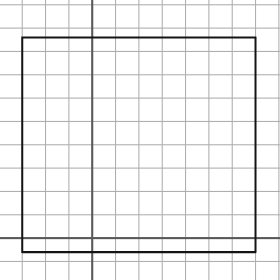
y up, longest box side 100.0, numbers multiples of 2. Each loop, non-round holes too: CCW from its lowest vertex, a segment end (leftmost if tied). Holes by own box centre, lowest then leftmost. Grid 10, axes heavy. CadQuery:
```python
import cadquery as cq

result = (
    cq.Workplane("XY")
    .moveTo(-30.0, -6.0)
    .lineTo(70.0, -6.0)
    .lineTo(70.0, 86.0)
    .lineTo(-30.0, 86.0)
    .close()
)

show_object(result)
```